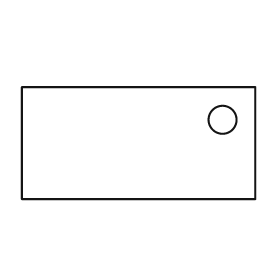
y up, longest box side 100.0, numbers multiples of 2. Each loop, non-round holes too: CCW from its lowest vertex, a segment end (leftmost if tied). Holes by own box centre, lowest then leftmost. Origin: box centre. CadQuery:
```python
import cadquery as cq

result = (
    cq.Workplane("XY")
    .moveTo(-50.0, -24.0)
    .lineTo(50.0, -24.0)
    .lineTo(50.0, 24.0)
    .lineTo(-50.0, 24.0)
    .close()
    .moveTo(36.0, 10.0)
    .circle(6.0)
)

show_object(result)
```